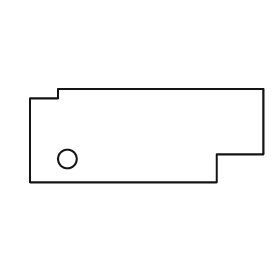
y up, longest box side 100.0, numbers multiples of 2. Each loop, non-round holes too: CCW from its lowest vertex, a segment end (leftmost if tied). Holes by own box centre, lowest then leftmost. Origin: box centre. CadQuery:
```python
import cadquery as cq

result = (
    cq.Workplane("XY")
    .moveTo(-50.0, -20.0)
    .lineTo(30.0, -20.0)
    .lineTo(30.0, -8.0)
    .lineTo(50.0, -8.0)
    .lineTo(50.0, 20.0)
    .lineTo(-38.0, 20.0)
    .lineTo(-38.0, 16.0)
    .lineTo(-50.0, 16.0)
    .close()
    .moveTo(-34.0, -10.0)
    .circle(4.0)
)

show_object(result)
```